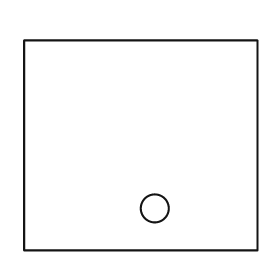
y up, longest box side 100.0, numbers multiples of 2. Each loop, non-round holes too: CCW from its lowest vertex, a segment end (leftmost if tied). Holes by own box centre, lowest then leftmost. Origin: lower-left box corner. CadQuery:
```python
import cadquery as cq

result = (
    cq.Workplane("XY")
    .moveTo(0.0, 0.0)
    .lineTo(100.0, 0.0)
    .lineTo(100.0, 90.0)
    .lineTo(0.0, 90.0)
    .close()
    .moveTo(56.0, 18.0)
    .circle(6.0)
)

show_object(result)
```